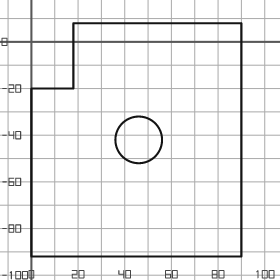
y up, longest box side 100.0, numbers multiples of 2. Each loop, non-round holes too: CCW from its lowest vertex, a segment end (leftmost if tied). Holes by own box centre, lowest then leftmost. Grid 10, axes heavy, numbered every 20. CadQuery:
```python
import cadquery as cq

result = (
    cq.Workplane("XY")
    .moveTo(0.0, -92.0)
    .lineTo(90.0, -92.0)
    .lineTo(90.0, 8.0)
    .lineTo(18.0, 8.0)
    .lineTo(18.0, -20.0)
    .lineTo(0.0, -20.0)
    .close()
    .moveTo(46.0, -42.0)
    .circle(10.0)
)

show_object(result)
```